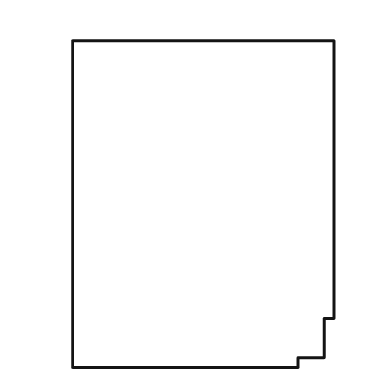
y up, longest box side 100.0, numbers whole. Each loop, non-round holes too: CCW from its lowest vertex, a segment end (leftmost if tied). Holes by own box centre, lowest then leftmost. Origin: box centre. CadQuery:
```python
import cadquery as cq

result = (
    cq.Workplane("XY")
    .moveTo(-40.0, -50.0)
    .lineTo(29.0, -50.0)
    .lineTo(29.0, -47.0)
    .lineTo(37.0, -47.0)
    .lineTo(37.0, -35.0)
    .lineTo(40.0, -35.0)
    .lineTo(40.0, 50.0)
    .lineTo(-40.0, 50.0)
    .close()
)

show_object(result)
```